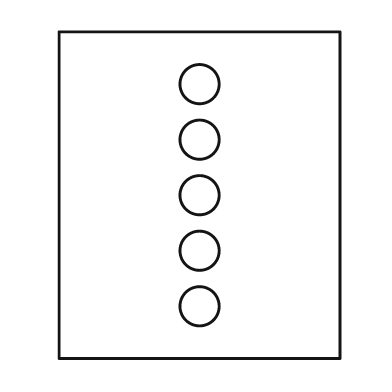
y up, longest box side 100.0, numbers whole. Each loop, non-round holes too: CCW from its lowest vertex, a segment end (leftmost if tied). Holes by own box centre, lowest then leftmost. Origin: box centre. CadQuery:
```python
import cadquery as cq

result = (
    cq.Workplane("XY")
    .moveTo(-43.0, -50.0)
    .lineTo(43.0, -50.0)
    .lineTo(43.0, 50.0)
    .lineTo(-43.0, 50.0)
    .close()
    .moveTo(0.0, -34.0)
    .circle(6.0)
    .moveTo(0.0, -17.0)
    .circle(6.0)
    .moveTo(0.0, 0.0)
    .circle(6.0)
    .moveTo(0.0, 17.0)
    .circle(6.0)
    .moveTo(0.0, 34.0)
    .circle(6.0)
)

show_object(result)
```